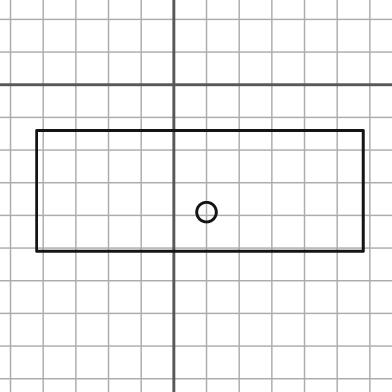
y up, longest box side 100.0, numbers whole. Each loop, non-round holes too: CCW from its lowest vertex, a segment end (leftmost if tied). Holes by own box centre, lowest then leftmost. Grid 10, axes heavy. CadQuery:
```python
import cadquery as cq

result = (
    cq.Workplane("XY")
    .moveTo(-42.0, -51.0)
    .lineTo(58.0, -51.0)
    .lineTo(58.0, -14.0)
    .lineTo(-42.0, -14.0)
    .close()
    .moveTo(10.0, -39.0)
    .circle(3.0)
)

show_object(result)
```